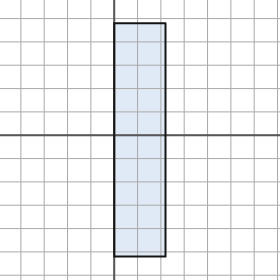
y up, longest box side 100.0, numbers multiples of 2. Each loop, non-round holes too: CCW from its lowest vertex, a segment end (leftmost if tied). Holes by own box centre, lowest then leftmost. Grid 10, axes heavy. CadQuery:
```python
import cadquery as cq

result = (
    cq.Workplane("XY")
    .moveTo(0.0, -52.0)
    .lineTo(22.0, -52.0)
    .lineTo(22.0, 48.0)
    .lineTo(0.0, 48.0)
    .close()
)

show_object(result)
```